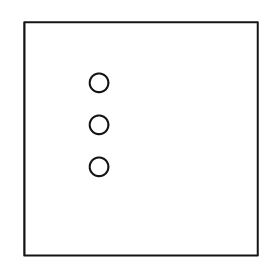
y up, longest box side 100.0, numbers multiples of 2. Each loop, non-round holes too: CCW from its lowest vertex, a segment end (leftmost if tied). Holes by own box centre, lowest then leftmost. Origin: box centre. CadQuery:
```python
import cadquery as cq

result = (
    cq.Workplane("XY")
    .moveTo(-50.0, -50.0)
    .lineTo(50.0, -50.0)
    .lineTo(50.0, 50.0)
    .lineTo(-50.0, 50.0)
    .close()
    .moveTo(-18.0, -12.0)
    .circle(4.0)
    .moveTo(-18.0, 6.0)
    .circle(4.0)
    .moveTo(-18.0, 24.0)
    .circle(4.0)
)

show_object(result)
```